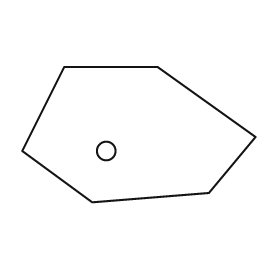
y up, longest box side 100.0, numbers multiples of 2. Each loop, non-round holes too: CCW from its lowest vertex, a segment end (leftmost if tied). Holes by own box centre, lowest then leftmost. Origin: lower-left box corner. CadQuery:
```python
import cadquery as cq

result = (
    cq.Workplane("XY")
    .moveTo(30.0, 0.0)
    .lineTo(80.0, 4.0)
    .lineTo(100.0, 28.0)
    .lineTo(58.0, 58.0)
    .lineTo(18.0, 58.0)
    .lineTo(0.0, 22.0)
    .close()
    .moveTo(36.0, 22.0)
    .circle(4.0)
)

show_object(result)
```